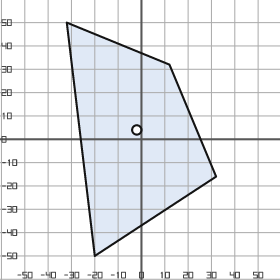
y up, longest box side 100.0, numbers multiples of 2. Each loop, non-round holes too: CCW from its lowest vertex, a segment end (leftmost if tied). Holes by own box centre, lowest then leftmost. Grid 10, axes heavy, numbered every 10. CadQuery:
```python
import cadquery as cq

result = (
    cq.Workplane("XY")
    .moveTo(-20.0, -50.0)
    .lineTo(32.0, -16.0)
    .lineTo(12.0, 32.0)
    .lineTo(-32.0, 50.0)
    .close()
    .moveTo(-2.0, 4.0)
    .circle(2.0)
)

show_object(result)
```